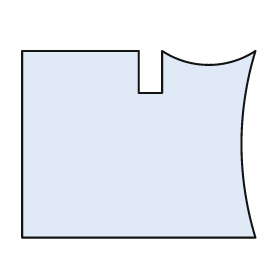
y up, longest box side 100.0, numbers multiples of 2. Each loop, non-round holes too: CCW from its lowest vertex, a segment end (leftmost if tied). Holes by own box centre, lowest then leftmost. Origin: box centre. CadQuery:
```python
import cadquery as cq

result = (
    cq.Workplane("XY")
    .moveTo(-50.0, -40.0)
    .lineTo(50.0, -40.0)
    .threePointArc((44.0, 0.0), (50.0, 40.0))
    .threePointArc((30.0, 34.0), (10.0, 40.0))
    .lineTo(10.0, 22.0)
    .lineTo(0.0, 22.0)
    .lineTo(0.0, 40.0)
    .lineTo(-50.0, 40.0)
    .close()
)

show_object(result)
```